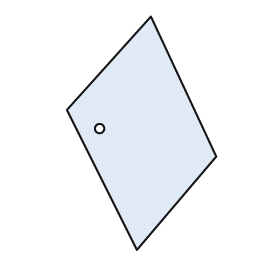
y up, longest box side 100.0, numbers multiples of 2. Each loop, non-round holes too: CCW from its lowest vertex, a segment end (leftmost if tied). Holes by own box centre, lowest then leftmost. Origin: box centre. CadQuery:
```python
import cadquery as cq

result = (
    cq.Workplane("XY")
    .moveTo(-2.0, -50.0)
    .lineTo(32.0, -10.0)
    .lineTo(4.0, 50.0)
    .lineTo(-32.0, 10.0)
    .close()
    .moveTo(-18.0, 2.0)
    .circle(2.0)
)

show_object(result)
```